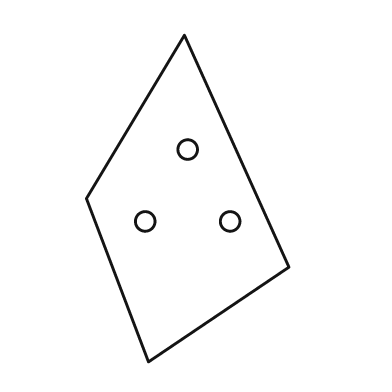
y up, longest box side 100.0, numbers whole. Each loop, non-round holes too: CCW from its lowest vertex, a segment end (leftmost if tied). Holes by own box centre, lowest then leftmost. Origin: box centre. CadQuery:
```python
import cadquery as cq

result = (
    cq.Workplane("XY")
    .moveTo(-12.0, -50.0)
    .lineTo(31.0, -21.0)
    .lineTo(-1.0, 50.0)
    .lineTo(-31.0, 0.0)
    .close()
    .moveTo(-13.0, -7.0)
    .circle(3.0)
    .moveTo(13.0, -7.0)
    .circle(3.0)
    .moveTo(0.0, 15.0)
    .circle(3.0)
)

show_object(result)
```